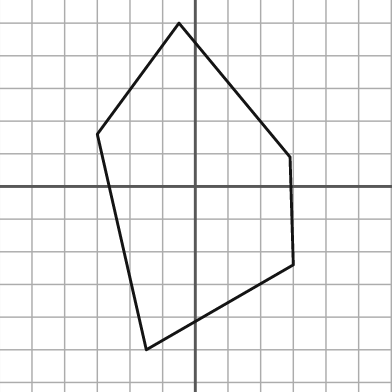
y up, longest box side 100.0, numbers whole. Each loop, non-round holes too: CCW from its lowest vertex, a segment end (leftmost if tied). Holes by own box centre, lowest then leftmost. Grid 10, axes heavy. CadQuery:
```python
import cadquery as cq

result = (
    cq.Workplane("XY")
    .moveTo(-15.0, -50.0)
    .lineTo(30.0, -24.0)
    .lineTo(29.0, 9.0)
    .lineTo(-5.0, 50.0)
    .lineTo(-30.0, 16.0)
    .close()
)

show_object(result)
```